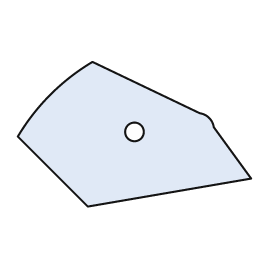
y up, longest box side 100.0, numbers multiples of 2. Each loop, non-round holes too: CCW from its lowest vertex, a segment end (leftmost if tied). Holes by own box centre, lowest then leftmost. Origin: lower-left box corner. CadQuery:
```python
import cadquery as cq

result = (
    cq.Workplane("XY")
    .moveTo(30.0, 0.0)
    .lineTo(100.0, 12.0)
    .lineTo(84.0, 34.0)
    .threePointArc((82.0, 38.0), (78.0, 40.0))
    .lineTo(32.0, 62.0)
    .threePointArc((14.0, 48.0), (0.0, 30.0))
    .close()
    .moveTo(50.0, 32.0)
    .circle(4.0)
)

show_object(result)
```